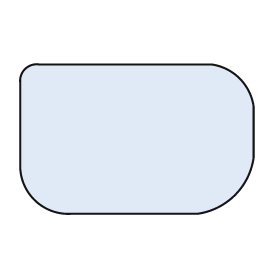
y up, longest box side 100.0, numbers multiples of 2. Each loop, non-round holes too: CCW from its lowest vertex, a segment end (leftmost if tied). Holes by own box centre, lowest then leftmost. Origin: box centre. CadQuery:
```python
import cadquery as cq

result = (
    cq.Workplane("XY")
    .moveTo(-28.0, -32.0)
    .lineTo(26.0, -32.0)
    .threePointArc((42.0, -24.0), (50.0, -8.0))
    .lineTo(50.0, 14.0)
    .threePointArc((44.0, 26.0), (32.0, 32.0))
    .lineTo(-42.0, 32.0)
    .threePointArc((-48.0, 30.0), (-50.0, 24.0))
    .lineTo(-50.0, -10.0)
    .threePointArc((-44.0, -26.0), (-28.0, -32.0))
    .close()
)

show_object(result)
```